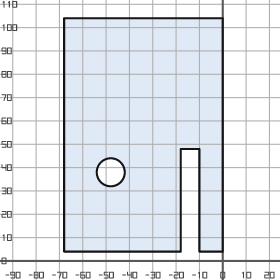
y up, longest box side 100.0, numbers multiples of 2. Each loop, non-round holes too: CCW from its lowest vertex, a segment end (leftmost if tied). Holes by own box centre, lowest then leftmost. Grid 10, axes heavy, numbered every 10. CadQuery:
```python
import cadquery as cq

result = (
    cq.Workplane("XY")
    .moveTo(-68.0, 4.0)
    .lineTo(-18.0, 4.0)
    .lineTo(-18.0, 48.0)
    .lineTo(-10.0, 48.0)
    .lineTo(-10.0, 4.0)
    .lineTo(0.0, 4.0)
    .lineTo(0.0, 104.0)
    .lineTo(-68.0, 104.0)
    .close()
    .moveTo(-48.0, 38.0)
    .circle(6.0)
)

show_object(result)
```